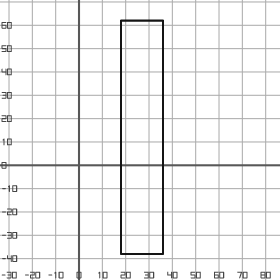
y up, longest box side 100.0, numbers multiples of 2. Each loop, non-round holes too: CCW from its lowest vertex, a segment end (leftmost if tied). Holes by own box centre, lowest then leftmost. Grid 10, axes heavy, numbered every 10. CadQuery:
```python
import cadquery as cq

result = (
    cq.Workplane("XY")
    .moveTo(18.0, -38.0)
    .lineTo(36.0, -38.0)
    .lineTo(36.0, 62.0)
    .lineTo(18.0, 62.0)
    .close()
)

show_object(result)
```